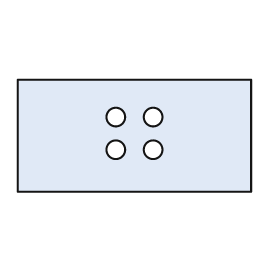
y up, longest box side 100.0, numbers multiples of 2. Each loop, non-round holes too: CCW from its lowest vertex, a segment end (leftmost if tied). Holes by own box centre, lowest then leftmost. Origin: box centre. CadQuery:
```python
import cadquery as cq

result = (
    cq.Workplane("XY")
    .moveTo(-50.0, -24.0)
    .lineTo(50.0, -24.0)
    .lineTo(50.0, 24.0)
    .lineTo(-50.0, 24.0)
    .close()
    .moveTo(-8.0, -6.0)
    .circle(4.0)
    .moveTo(8.0, -6.0)
    .circle(4.0)
    .moveTo(-8.0, 8.0)
    .circle(4.0)
    .moveTo(8.0, 8.0)
    .circle(4.0)
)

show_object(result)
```